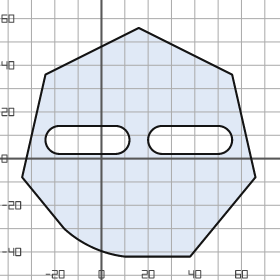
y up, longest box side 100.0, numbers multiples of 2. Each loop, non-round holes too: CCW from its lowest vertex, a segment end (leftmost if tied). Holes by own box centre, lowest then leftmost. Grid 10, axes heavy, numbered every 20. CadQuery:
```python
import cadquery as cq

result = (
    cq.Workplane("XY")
    .moveTo(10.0, -42.0)
    .lineTo(38.0, -42.0)
    .lineTo(66.0, -8.0)
    .lineTo(56.0, 36.0)
    .lineTo(16.0, 56.0)
    .lineTo(-24.0, 36.0)
    .lineTo(-34.0, -8.0)
    .lineTo(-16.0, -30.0)
    .threePointArc((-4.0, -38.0), (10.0, -42.0))
    .close()
    .moveTo(-18.0, 2.0)
    .lineTo(6.0, 2.0)
    .threePointArc((12.0, 8.0), (6.0, 14.0))
    .lineTo(-18.0, 14.0)
    .threePointArc((-24.0, 8.0), (-18.0, 2.0))
    .close()
    .moveTo(26.0, 2.0)
    .lineTo(50.0, 2.0)
    .threePointArc((56.0, 8.0), (50.0, 14.0))
    .lineTo(26.0, 14.0)
    .threePointArc((20.0, 8.0), (26.0, 2.0))
    .close()
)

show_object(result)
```